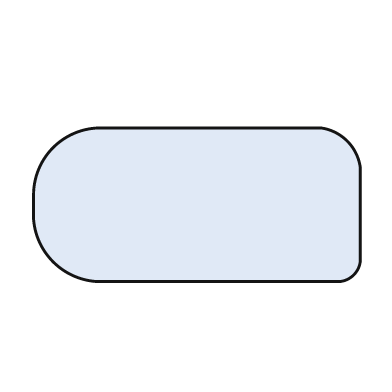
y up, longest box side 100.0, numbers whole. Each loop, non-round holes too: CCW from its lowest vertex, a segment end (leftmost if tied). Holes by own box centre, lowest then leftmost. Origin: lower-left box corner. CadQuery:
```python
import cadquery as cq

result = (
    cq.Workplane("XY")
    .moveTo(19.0, 0.0)
    .lineTo(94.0, 0.0)
    .threePointArc((98.0, 2.0), (100.0, 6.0))
    .lineTo(100.0, 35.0)
    .threePointArc((96.0, 43.0), (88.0, 47.0))
    .lineTo(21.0, 47.0)
    .threePointArc((6.0, 41.0), (0.0, 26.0))
    .lineTo(0.0, 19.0)
    .threePointArc((6.0, 6.0), (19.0, 0.0))
    .close()
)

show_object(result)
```